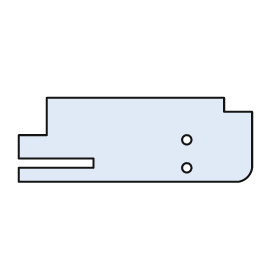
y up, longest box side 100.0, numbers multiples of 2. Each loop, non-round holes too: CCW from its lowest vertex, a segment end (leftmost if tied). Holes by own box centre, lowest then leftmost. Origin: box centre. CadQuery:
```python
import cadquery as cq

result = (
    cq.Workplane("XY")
    .moveTo(-50.0, -18.0)
    .lineTo(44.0, -18.0)
    .threePointArc((48.0, -16.0), (50.0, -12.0))
    .lineTo(50.0, 12.0)
    .lineTo(38.0, 12.0)
    .lineTo(38.0, 18.0)
    .lineTo(-38.0, 18.0)
    .lineTo(-38.0, 2.0)
    .lineTo(-50.0, 2.0)
    .lineTo(-50.0, -8.0)
    .lineTo(-18.0, -8.0)
    .lineTo(-18.0, -12.0)
    .lineTo(-50.0, -12.0)
    .close()
    .moveTo(22.0, -12.0)
    .circle(2.0)
    .moveTo(22.0, 0.0)
    .circle(2.0)
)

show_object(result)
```